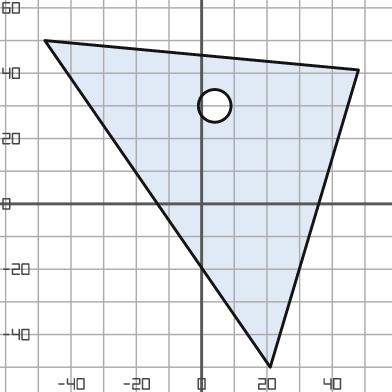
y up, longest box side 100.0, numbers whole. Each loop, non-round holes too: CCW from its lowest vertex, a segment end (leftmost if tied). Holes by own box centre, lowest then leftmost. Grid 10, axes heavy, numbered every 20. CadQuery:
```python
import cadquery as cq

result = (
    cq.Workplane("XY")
    .moveTo(21.0, -50.0)
    .lineTo(48.0, 41.0)
    .lineTo(-48.0, 50.0)
    .close()
    .moveTo(4.0, 30.0)
    .circle(5.0)
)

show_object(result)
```